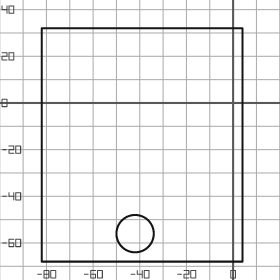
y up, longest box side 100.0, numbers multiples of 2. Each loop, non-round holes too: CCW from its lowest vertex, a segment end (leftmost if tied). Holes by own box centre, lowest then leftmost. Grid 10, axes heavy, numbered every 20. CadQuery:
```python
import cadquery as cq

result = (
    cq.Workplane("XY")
    .moveTo(-82.0, -68.0)
    .lineTo(4.0, -68.0)
    .lineTo(4.0, 32.0)
    .lineTo(-82.0, 32.0)
    .close()
    .moveTo(-42.0, -56.0)
    .circle(8.0)
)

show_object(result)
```